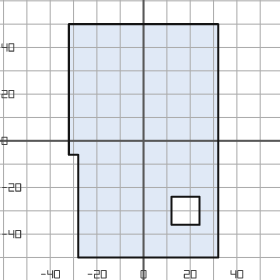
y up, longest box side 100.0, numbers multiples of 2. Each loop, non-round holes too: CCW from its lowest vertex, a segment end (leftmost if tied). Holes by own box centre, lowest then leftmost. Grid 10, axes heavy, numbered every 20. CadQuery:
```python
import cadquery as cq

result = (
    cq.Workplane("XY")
    .moveTo(-28.0, -50.0)
    .lineTo(32.0, -50.0)
    .lineTo(32.0, 50.0)
    .lineTo(-32.0, 50.0)
    .lineTo(-32.0, -6.0)
    .lineTo(-28.0, -6.0)
    .close()
    .moveTo(12.0, -36.0)
    .lineTo(24.0, -36.0)
    .lineTo(24.0, -24.0)
    .lineTo(12.0, -24.0)
    .close()
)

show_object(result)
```